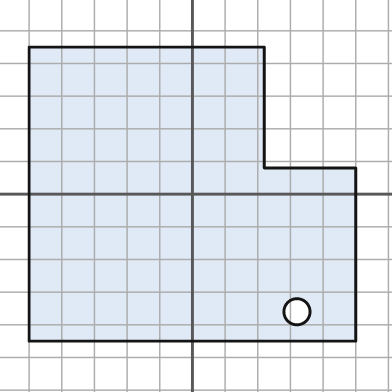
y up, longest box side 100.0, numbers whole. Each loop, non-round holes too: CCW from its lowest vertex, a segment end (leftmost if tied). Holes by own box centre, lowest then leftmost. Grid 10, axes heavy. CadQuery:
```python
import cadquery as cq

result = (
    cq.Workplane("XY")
    .moveTo(-50.0, -45.0)
    .lineTo(50.0, -45.0)
    .lineTo(50.0, 8.0)
    .lineTo(22.0, 8.0)
    .lineTo(22.0, 45.0)
    .lineTo(-50.0, 45.0)
    .close()
    .moveTo(32.0, -36.0)
    .circle(4.0)
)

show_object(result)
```